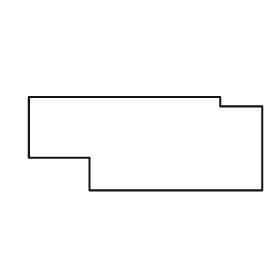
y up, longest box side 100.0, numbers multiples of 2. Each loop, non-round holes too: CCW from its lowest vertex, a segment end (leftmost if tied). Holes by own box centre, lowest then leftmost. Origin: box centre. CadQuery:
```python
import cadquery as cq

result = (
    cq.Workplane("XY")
    .moveTo(-24.0, -20.0)
    .lineTo(50.0, -20.0)
    .lineTo(50.0, 16.0)
    .lineTo(32.0, 16.0)
    .lineTo(32.0, 20.0)
    .lineTo(-50.0, 20.0)
    .lineTo(-50.0, -6.0)
    .lineTo(-24.0, -6.0)
    .close()
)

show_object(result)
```